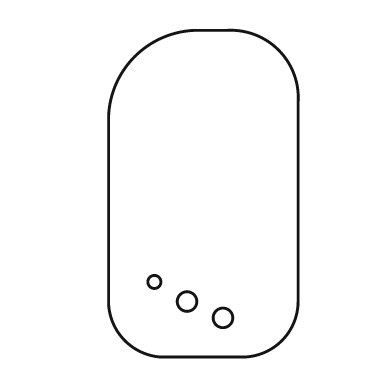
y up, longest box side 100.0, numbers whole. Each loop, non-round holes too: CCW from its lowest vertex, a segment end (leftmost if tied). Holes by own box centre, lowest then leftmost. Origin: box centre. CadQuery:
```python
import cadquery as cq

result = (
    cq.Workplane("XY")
    .moveTo(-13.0, -50.0)
    .lineTo(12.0, -50.0)
    .threePointArc((24.0, -45.0), (29.0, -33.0))
    .lineTo(29.0, 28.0)
    .threePointArc((23.0, 44.0), (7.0, 50.0))
    .lineTo(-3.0, 50.0)
    .threePointArc((-21.0, 42.0), (-29.0, 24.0))
    .lineTo(-29.0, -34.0)
    .threePointArc((-24.0, -45.0), (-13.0, -50.0))
    .close()
    .moveTo(6.0, -38.0)
    .circle(3.0)
    .moveTo(-5.0, -33.0)
    .circle(3.0)
    .moveTo(-15.0, -27.0)
    .circle(2.0)
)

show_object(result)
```